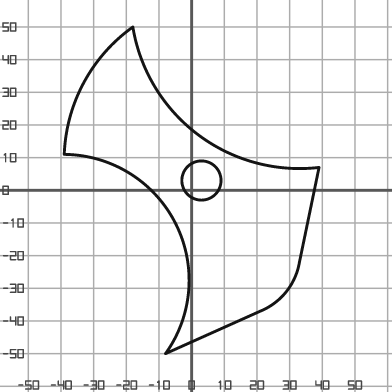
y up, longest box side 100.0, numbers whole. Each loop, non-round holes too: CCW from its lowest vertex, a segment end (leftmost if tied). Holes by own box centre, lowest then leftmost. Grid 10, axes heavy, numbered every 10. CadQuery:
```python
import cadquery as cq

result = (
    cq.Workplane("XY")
    .moveTo(-8.0, -50.0)
    .lineTo(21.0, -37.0)
    .threePointArc((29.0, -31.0), (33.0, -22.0))
    .lineTo(39.0, 7.0)
    .threePointArc((2.0, 17.0), (-18.0, 50.0))
    .threePointArc((-33.0, 33.0), (-39.0, 11.0))
    .threePointArc((-5.0, -10.0), (-8.0, -50.0))
    .close()
    .moveTo(3.0, 3.0)
    .circle(6.0)
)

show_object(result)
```